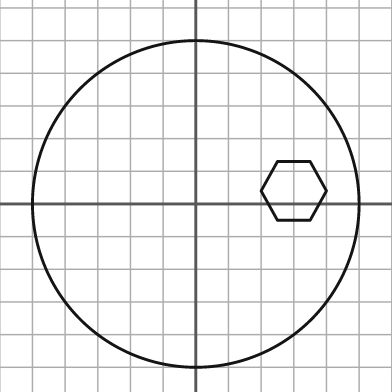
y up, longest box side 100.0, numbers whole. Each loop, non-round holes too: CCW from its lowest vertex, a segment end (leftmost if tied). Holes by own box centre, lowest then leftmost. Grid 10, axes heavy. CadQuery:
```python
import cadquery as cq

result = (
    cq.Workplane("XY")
    .moveTo(0.0, 0.0)
    .circle(50.0)
    .moveTo(25.0, -5.0)
    .lineTo(35.0, -5.0)
    .lineTo(40.0, 4.0)
    .lineTo(35.0, 13.0)
    .lineTo(25.0, 13.0)
    .lineTo(20.0, 4.0)
    .close()
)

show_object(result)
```